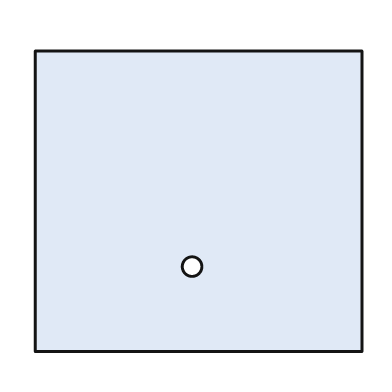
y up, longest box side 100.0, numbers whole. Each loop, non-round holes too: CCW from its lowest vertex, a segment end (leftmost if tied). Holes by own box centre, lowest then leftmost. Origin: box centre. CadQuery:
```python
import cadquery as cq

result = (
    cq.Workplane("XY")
    .moveTo(-50.0, -46.0)
    .lineTo(50.0, -46.0)
    .lineTo(50.0, 46.0)
    .lineTo(-50.0, 46.0)
    .close()
    .moveTo(-2.0, -20.0)
    .circle(3.0)
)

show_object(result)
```